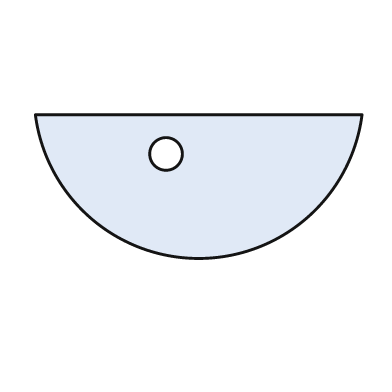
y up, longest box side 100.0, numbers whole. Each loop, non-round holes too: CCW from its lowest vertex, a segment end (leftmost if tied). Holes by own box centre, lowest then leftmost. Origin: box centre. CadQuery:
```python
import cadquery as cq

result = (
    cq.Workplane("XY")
    .moveTo(-50.0, 22.0)
    .threePointArc((0.0, -22.0), (50.0, 22.0))
    .close()
    .moveTo(-10.0, 10.0)
    .circle(5.0)
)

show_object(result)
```